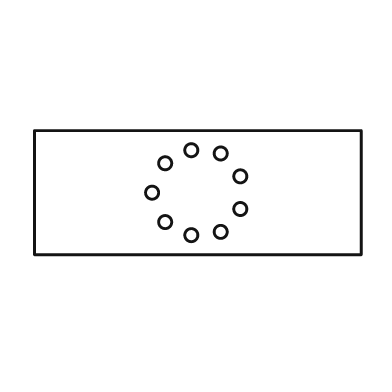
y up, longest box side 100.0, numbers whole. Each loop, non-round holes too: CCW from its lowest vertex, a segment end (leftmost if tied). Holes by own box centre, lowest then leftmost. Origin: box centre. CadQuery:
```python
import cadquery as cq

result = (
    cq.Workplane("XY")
    .moveTo(-50.0, -19.0)
    .lineTo(50.0, -19.0)
    .lineTo(50.0, 19.0)
    .lineTo(-50.0, 19.0)
    .close()
    .moveTo(-2.0, -13.0)
    .circle(2.0)
    .moveTo(7.0, -12.0)
    .circle(2.0)
    .moveTo(-10.0, -9.0)
    .circle(2.0)
    .moveTo(13.0, -5.0)
    .circle(2.0)
    .moveTo(-14.0, 0.0)
    .circle(2.0)
    .moveTo(13.0, 5.0)
    .circle(2.0)
    .moveTo(-10.0, 9.0)
    .circle(2.0)
    .moveTo(7.0, 12.0)
    .circle(2.0)
    .moveTo(-2.0, 13.0)
    .circle(2.0)
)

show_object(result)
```